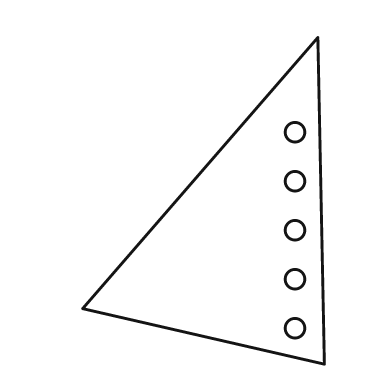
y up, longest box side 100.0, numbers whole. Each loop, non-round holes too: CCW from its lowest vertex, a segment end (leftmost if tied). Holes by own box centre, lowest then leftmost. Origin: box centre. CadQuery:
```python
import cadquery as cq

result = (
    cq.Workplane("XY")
    .moveTo(37.0, -50.0)
    .lineTo(35.0, 50.0)
    .lineTo(-37.0, -33.0)
    .close()
    .moveTo(28.0, -39.0)
    .circle(3.0)
    .moveTo(28.0, -24.0)
    .circle(3.0)
    .moveTo(28.0, -9.0)
    .circle(3.0)
    .moveTo(28.0, 6.0)
    .circle(3.0)
    .moveTo(28.0, 21.0)
    .circle(3.0)
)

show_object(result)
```